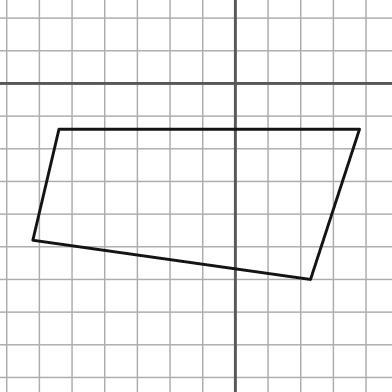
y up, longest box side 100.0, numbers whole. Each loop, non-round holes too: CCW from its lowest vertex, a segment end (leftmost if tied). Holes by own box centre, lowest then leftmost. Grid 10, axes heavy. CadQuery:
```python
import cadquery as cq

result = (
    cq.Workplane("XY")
    .moveTo(23.0, -60.0)
    .lineTo(38.0, -14.0)
    .lineTo(-54.0, -14.0)
    .lineTo(-62.0, -48.0)
    .close()
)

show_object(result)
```